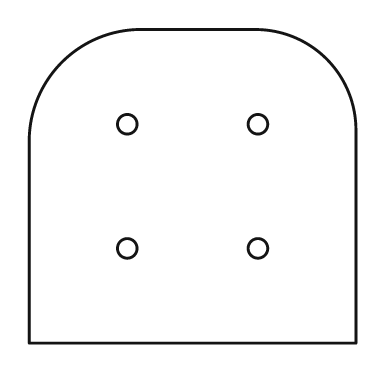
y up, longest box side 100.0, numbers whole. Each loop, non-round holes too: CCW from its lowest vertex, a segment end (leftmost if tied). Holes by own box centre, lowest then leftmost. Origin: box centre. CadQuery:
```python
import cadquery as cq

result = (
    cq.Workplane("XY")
    .moveTo(-50.0, -48.0)
    .lineTo(50.0, -48.0)
    .lineTo(50.0, 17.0)
    .threePointArc((41.0, 39.0), (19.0, 48.0))
    .lineTo(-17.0, 48.0)
    .threePointArc((-40.0, 38.0), (-50.0, 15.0))
    .close()
    .moveTo(-20.0, -19.0)
    .circle(3.0)
    .moveTo(20.0, -19.0)
    .circle(3.0)
    .moveTo(-20.0, 19.0)
    .circle(3.0)
    .moveTo(20.0, 19.0)
    .circle(3.0)
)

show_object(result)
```